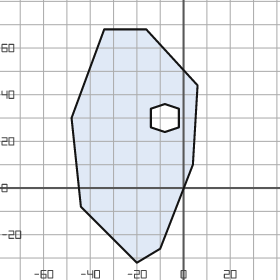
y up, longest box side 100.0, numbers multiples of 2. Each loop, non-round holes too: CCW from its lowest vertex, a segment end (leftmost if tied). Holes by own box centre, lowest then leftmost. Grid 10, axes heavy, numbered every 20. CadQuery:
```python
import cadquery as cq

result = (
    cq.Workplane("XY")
    .moveTo(-20.0, -32.0)
    .lineTo(-10.0, -26.0)
    .lineTo(4.0, 10.0)
    .lineTo(6.0, 44.0)
    .lineTo(-16.0, 68.0)
    .lineTo(-34.0, 68.0)
    .lineTo(-48.0, 30.0)
    .lineTo(-44.0, -8.0)
    .close()
    .moveTo(-8.0, 24.0)
    .lineTo(-2.0, 26.0)
    .lineTo(-2.0, 34.0)
    .lineTo(-8.0, 36.0)
    .lineTo(-14.0, 34.0)
    .lineTo(-14.0, 26.0)
    .close()
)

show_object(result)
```